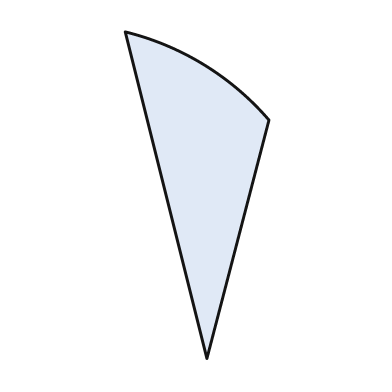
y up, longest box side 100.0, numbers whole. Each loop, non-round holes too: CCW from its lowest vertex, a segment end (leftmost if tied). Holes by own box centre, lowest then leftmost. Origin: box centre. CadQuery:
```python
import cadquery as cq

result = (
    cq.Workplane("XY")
    .moveTo(3.0, -50.0)
    .lineTo(22.0, 23.0)
    .threePointArc((2.0, 40.0), (-22.0, 50.0))
    .close()
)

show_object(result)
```